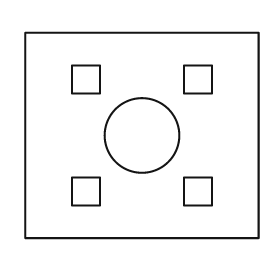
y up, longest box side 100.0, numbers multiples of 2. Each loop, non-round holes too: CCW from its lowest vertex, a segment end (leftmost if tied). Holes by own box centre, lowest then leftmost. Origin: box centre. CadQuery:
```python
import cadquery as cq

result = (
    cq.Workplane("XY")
    .moveTo(-50.0, -44.0)
    .lineTo(50.0, -44.0)
    .lineTo(50.0, 44.0)
    .lineTo(-50.0, 44.0)
    .close()
    .moveTo(-30.0, -30.0)
    .lineTo(-18.0, -30.0)
    .lineTo(-18.0, -18.0)
    .lineTo(-30.0, -18.0)
    .close()
    .moveTo(18.0, -30.0)
    .lineTo(30.0, -30.0)
    .lineTo(30.0, -18.0)
    .lineTo(18.0, -18.0)
    .close()
    .moveTo(0.0, 0.0)
    .circle(16.0)
    .moveTo(-30.0, 18.0)
    .lineTo(-18.0, 18.0)
    .lineTo(-18.0, 30.0)
    .lineTo(-30.0, 30.0)
    .close()
    .moveTo(18.0, 18.0)
    .lineTo(30.0, 18.0)
    .lineTo(30.0, 30.0)
    .lineTo(18.0, 30.0)
    .close()
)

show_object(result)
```